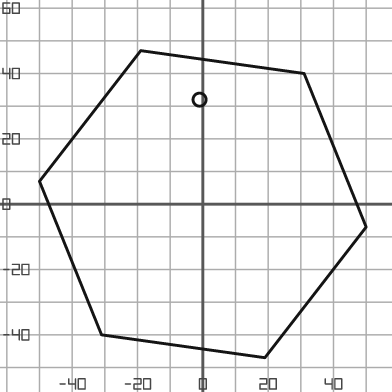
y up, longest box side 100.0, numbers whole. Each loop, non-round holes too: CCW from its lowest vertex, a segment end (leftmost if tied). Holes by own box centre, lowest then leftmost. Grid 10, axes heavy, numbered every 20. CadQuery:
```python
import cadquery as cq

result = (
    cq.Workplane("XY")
    .moveTo(19.0, -47.0)
    .lineTo(50.0, -7.0)
    .lineTo(31.0, 40.0)
    .lineTo(-19.0, 47.0)
    .lineTo(-50.0, 7.0)
    .lineTo(-31.0, -40.0)
    .close()
    .moveTo(-1.0, 32.0)
    .circle(2.0)
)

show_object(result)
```